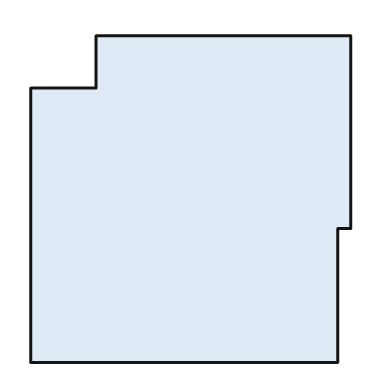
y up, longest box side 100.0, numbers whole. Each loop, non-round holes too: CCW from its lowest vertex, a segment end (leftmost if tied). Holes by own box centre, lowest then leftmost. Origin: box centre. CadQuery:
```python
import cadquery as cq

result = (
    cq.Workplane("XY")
    .moveTo(-49.0, -50.0)
    .lineTo(45.0, -50.0)
    .lineTo(45.0, -9.0)
    .lineTo(49.0, -9.0)
    .lineTo(49.0, 50.0)
    .lineTo(-29.0, 50.0)
    .lineTo(-29.0, 34.0)
    .lineTo(-49.0, 34.0)
    .close()
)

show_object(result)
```